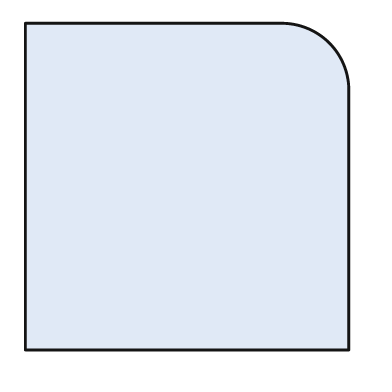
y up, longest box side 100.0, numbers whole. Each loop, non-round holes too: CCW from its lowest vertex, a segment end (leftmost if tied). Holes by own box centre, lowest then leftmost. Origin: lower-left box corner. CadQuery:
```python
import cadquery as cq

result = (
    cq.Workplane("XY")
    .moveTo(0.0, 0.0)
    .lineTo(99.0, 0.0)
    .lineTo(99.0, 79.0)
    .threePointArc((93.0, 94.0), (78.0, 100.0))
    .lineTo(0.0, 100.0)
    .close()
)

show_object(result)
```